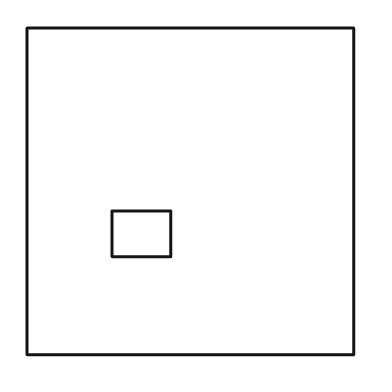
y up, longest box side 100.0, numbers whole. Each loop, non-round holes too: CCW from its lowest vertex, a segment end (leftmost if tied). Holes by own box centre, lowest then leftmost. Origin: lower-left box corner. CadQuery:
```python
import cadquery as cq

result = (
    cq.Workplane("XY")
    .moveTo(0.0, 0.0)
    .lineTo(100.0, 0.0)
    .lineTo(100.0, 100.0)
    .lineTo(0.0, 100.0)
    .close()
    .moveTo(26.0, 30.0)
    .lineTo(44.0, 30.0)
    .lineTo(44.0, 44.0)
    .lineTo(26.0, 44.0)
    .close()
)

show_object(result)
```